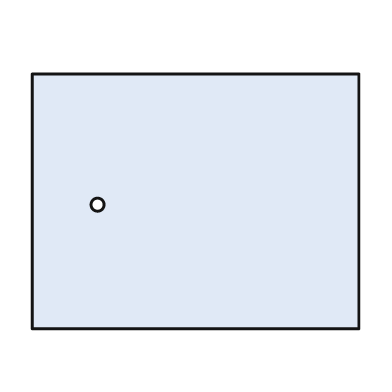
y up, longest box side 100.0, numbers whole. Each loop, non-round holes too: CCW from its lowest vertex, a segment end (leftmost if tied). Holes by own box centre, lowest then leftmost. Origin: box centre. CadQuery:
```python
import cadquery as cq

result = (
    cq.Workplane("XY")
    .moveTo(-50.0, -39.0)
    .lineTo(50.0, -39.0)
    .lineTo(50.0, 39.0)
    .lineTo(-50.0, 39.0)
    .close()
    .moveTo(-30.0, -1.0)
    .circle(2.0)
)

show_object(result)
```